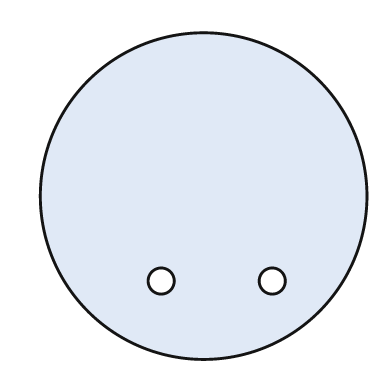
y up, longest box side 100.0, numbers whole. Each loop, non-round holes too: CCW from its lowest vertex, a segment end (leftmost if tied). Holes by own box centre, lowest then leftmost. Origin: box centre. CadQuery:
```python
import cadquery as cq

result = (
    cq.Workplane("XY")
    .moveTo(0.0, 0.0)
    .circle(50.0)
    .moveTo(-13.0, -26.0)
    .circle(4.0)
    .moveTo(21.0, -26.0)
    .circle(4.0)
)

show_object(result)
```